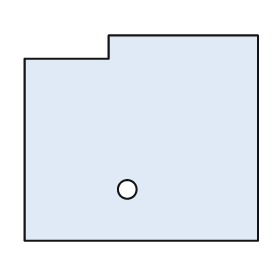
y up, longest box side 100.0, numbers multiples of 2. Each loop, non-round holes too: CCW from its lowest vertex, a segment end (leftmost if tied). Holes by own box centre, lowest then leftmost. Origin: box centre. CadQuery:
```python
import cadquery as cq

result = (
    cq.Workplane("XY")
    .moveTo(-50.0, -44.0)
    .lineTo(50.0, -44.0)
    .lineTo(50.0, 44.0)
    .lineTo(-14.0, 44.0)
    .lineTo(-14.0, 34.0)
    .lineTo(-50.0, 34.0)
    .close()
    .moveTo(-6.0, -22.0)
    .circle(4.0)
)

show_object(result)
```